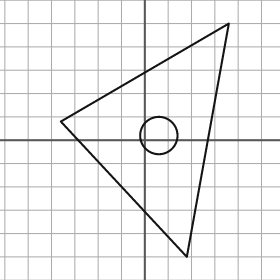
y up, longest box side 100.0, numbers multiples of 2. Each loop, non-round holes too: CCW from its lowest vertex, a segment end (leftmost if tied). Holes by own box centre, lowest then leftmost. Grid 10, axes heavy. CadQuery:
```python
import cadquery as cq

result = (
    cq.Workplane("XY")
    .moveTo(18.0, -50.0)
    .lineTo(36.0, 50.0)
    .lineTo(-36.0, 8.0)
    .close()
    .moveTo(6.0, 2.0)
    .circle(8.0)
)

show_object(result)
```